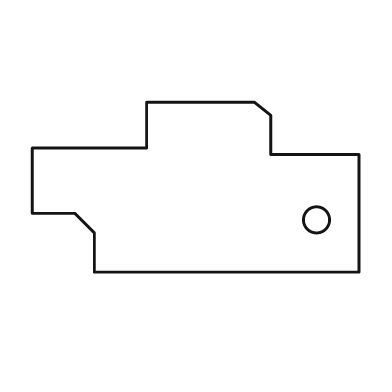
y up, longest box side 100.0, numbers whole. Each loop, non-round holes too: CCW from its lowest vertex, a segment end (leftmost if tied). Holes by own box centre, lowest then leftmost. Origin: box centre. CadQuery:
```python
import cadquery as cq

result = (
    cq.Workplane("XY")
    .moveTo(-31.0, -26.0)
    .lineTo(50.0, -26.0)
    .lineTo(50.0, 10.0)
    .lineTo(23.0, 10.0)
    .lineTo(23.0, 22.0)
    .lineTo(18.0, 26.0)
    .lineTo(-15.0, 26.0)
    .lineTo(-15.0, 12.0)
    .lineTo(-50.0, 12.0)
    .lineTo(-50.0, -8.0)
    .lineTo(-37.0, -8.0)
    .lineTo(-31.0, -14.0)
    .close()
    .moveTo(37.0, -10.0)
    .circle(4.0)
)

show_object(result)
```